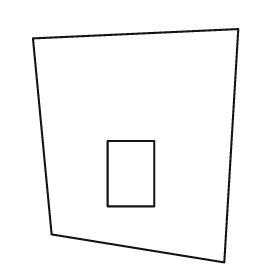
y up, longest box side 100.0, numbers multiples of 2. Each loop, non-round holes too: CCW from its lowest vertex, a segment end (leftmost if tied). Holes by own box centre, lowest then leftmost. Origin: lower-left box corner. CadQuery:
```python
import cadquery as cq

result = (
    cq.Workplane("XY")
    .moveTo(82.0, 0.0)
    .lineTo(88.0, 100.0)
    .lineTo(0.0, 96.0)
    .lineTo(8.0, 12.0)
    .close()
    .moveTo(32.0, 24.0)
    .lineTo(52.0, 24.0)
    .lineTo(52.0, 52.0)
    .lineTo(32.0, 52.0)
    .close()
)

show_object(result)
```